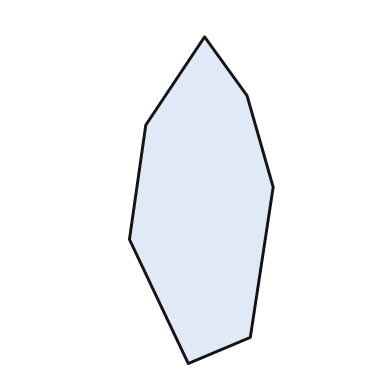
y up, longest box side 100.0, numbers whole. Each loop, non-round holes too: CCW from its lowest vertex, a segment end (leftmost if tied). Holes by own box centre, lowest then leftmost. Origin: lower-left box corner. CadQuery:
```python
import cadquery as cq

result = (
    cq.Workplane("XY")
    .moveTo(18.0, 0.0)
    .lineTo(37.0, 8.0)
    .lineTo(44.0, 54.0)
    .lineTo(36.0, 82.0)
    .lineTo(23.0, 100.0)
    .lineTo(5.0, 73.0)
    .lineTo(0.0, 38.0)
    .close()
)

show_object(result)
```